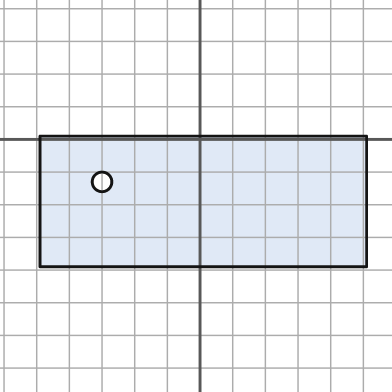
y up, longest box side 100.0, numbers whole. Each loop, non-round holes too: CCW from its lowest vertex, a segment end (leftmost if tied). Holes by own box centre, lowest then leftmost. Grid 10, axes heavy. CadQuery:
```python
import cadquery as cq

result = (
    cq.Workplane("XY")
    .moveTo(-49.0, -39.0)
    .lineTo(51.0, -39.0)
    .lineTo(51.0, 1.0)
    .lineTo(-49.0, 1.0)
    .close()
    .moveTo(-30.0, -13.0)
    .circle(3.0)
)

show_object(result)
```